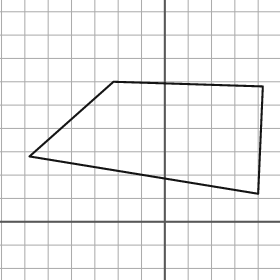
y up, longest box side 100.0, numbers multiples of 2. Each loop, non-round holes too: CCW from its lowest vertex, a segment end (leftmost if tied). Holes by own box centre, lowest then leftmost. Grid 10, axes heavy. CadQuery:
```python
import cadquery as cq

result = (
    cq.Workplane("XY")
    .moveTo(40.0, 12.0)
    .lineTo(42.0, 58.0)
    .lineTo(-22.0, 60.0)
    .lineTo(-58.0, 28.0)
    .close()
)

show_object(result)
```